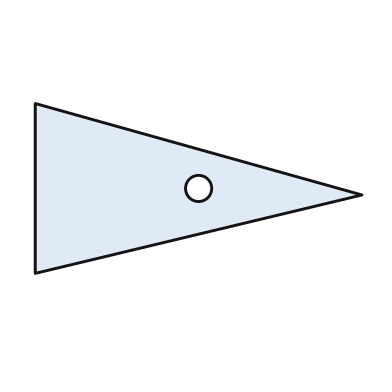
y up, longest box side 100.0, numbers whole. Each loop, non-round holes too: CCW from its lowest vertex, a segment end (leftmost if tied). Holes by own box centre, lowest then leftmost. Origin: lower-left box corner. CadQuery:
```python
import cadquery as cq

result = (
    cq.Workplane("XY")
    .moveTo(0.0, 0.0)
    .lineTo(100.0, 24.0)
    .lineTo(0.0, 52.0)
    .close()
    .moveTo(50.0, 26.0)
    .circle(4.0)
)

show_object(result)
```